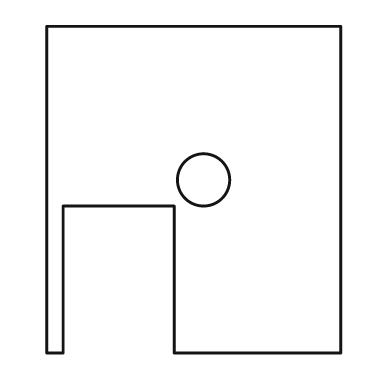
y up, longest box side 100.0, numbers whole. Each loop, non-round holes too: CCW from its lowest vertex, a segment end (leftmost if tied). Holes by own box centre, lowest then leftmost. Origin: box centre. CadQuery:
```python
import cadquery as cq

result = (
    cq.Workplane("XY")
    .moveTo(-45.0, -50.0)
    .lineTo(-40.0, -50.0)
    .lineTo(-40.0, -5.0)
    .lineTo(-6.0, -5.0)
    .lineTo(-6.0, -50.0)
    .lineTo(45.0, -50.0)
    .lineTo(45.0, 50.0)
    .lineTo(-45.0, 50.0)
    .close()
    .moveTo(3.0, 3.0)
    .circle(8.0)
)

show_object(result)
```